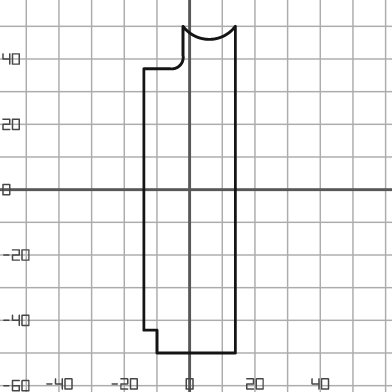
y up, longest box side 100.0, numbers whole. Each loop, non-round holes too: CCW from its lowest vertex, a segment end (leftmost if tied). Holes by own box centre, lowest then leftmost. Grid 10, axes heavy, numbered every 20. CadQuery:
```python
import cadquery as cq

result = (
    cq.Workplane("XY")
    .moveTo(-10.0, -50.0)
    .lineTo(14.0, -50.0)
    .lineTo(14.0, 50.0)
    .threePointArc((6.0, 46.0), (-2.0, 50.0))
    .lineTo(-2.0, 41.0)
    .threePointArc((-3.0, 38.0), (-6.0, 37.0))
    .lineTo(-14.0, 37.0)
    .lineTo(-14.0, -43.0)
    .lineTo(-10.0, -43.0)
    .close()
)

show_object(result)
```